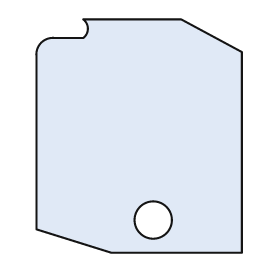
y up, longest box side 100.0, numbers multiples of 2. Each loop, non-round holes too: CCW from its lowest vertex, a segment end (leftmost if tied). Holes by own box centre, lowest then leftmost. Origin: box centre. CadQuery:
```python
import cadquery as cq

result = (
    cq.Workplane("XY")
    .moveTo(-12.0, -50.0)
    .lineTo(44.0, -50.0)
    .lineTo(44.0, 36.0)
    .lineTo(18.0, 50.0)
    .lineTo(-24.0, 50.0)
    .threePointArc((-22.0, 46.0), (-24.0, 42.0))
    .lineTo(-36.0, 42.0)
    .threePointArc((-42.0, 40.0), (-44.0, 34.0))
    .lineTo(-44.0, -40.0)
    .close()
    .moveTo(6.0, -36.0)
    .circle(8.0)
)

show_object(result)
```